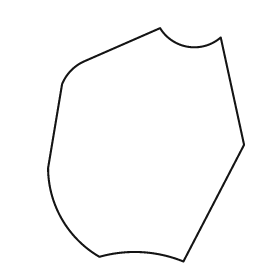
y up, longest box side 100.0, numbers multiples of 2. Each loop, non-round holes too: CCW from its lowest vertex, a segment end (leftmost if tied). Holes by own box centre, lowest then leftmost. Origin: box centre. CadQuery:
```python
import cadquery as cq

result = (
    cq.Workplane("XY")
    .moveTo(16.0, -50.0)
    .lineTo(42.0, 0.0)
    .lineTo(32.0, 46.0)
    .threePointArc((18.0, 42.0), (6.0, 50.0))
    .lineTo(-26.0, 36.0)
    .threePointArc((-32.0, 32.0), (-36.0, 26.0))
    .lineTo(-42.0, -10.0)
    .threePointArc((-36.0, -32.0), (-20.0, -48.0))
    .threePointArc((-2.0, -46.0), (16.0, -50.0))
    .close()
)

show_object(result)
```